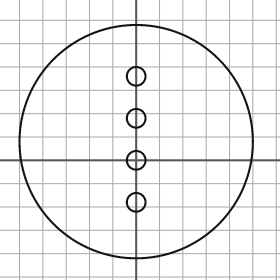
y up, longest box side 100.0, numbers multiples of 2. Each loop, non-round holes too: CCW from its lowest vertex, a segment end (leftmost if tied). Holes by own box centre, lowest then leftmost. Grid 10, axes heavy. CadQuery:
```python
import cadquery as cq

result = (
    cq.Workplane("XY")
    .moveTo(0.0, 8.0)
    .circle(50.0)
    .moveTo(0.0, -18.0)
    .circle(4.0)
    .moveTo(0.0, 0.0)
    .circle(4.0)
    .moveTo(0.0, 18.0)
    .circle(4.0)
    .moveTo(0.0, 36.0)
    .circle(4.0)
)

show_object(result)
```